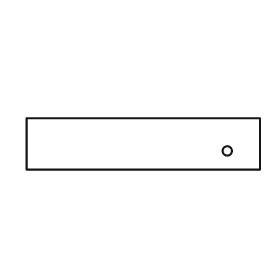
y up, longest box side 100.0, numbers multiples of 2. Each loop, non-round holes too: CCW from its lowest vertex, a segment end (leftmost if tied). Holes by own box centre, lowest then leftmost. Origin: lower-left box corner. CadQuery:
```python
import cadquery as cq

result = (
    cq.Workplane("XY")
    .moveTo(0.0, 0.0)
    .lineTo(100.0, 0.0)
    .lineTo(100.0, 22.0)
    .lineTo(0.0, 22.0)
    .close()
    .moveTo(86.0, 8.0)
    .circle(2.0)
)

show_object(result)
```